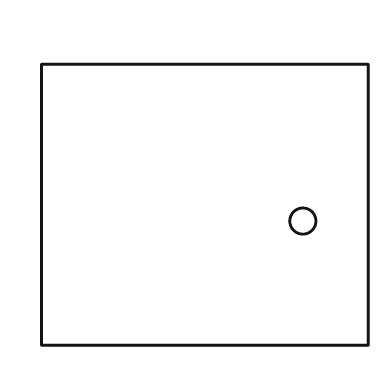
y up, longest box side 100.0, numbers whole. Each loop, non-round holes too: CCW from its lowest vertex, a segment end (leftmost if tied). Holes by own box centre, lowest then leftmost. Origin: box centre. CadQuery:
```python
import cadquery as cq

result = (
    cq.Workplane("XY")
    .moveTo(-50.0, -43.0)
    .lineTo(50.0, -43.0)
    .lineTo(50.0, 43.0)
    .lineTo(-50.0, 43.0)
    .close()
    .moveTo(30.0, -5.0)
    .circle(4.0)
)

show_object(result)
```